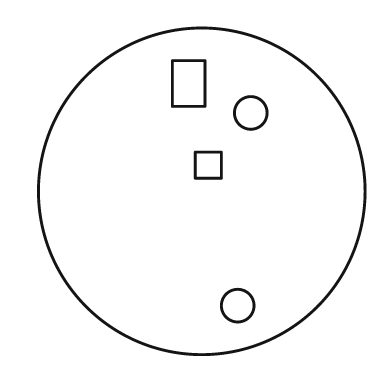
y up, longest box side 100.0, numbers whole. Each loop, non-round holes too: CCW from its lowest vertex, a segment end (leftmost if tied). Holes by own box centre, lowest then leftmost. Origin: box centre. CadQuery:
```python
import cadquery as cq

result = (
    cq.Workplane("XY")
    .moveTo(0.0, 0.0)
    .circle(50.0)
    .moveTo(11.0, -35.0)
    .circle(5.0)
    .moveTo(-2.0, 4.0)
    .lineTo(6.0, 4.0)
    .lineTo(6.0, 12.0)
    .lineTo(-2.0, 12.0)
    .close()
    .moveTo(15.0, 24.0)
    .circle(5.0)
    .moveTo(-9.0, 26.0)
    .lineTo(1.0, 26.0)
    .lineTo(1.0, 40.0)
    .lineTo(-9.0, 40.0)
    .close()
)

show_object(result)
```